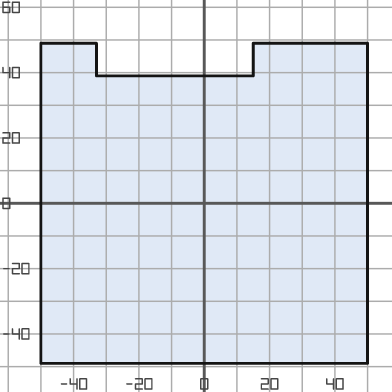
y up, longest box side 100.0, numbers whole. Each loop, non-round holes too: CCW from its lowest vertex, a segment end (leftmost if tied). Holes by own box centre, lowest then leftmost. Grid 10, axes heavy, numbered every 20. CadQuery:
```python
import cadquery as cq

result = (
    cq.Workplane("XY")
    .moveTo(-50.0, -49.0)
    .lineTo(50.0, -49.0)
    .lineTo(50.0, 49.0)
    .lineTo(15.0, 49.0)
    .lineTo(15.0, 39.0)
    .lineTo(-33.0, 39.0)
    .lineTo(-33.0, 49.0)
    .lineTo(-50.0, 49.0)
    .close()
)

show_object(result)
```